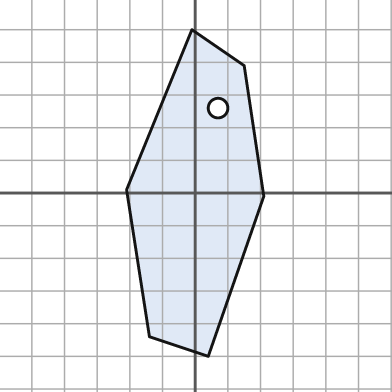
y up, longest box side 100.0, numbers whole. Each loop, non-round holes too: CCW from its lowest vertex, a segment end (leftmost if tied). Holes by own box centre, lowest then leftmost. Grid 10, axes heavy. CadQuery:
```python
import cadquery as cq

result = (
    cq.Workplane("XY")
    .moveTo(4.0, -50.0)
    .lineTo(21.0, -1.0)
    .lineTo(15.0, 39.0)
    .lineTo(-1.0, 50.0)
    .lineTo(-21.0, 1.0)
    .lineTo(-14.0, -44.0)
    .close()
    .moveTo(7.0, 26.0)
    .circle(3.0)
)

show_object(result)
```